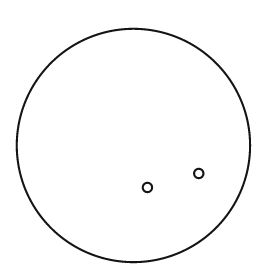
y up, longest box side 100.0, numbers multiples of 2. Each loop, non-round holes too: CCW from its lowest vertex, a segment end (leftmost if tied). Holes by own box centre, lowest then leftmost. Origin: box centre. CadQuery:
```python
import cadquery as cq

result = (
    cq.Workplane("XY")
    .moveTo(0.0, 0.0)
    .circle(50.0)
    .moveTo(6.0, -18.0)
    .circle(2.0)
    .moveTo(28.0, -12.0)
    .circle(2.0)
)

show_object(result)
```